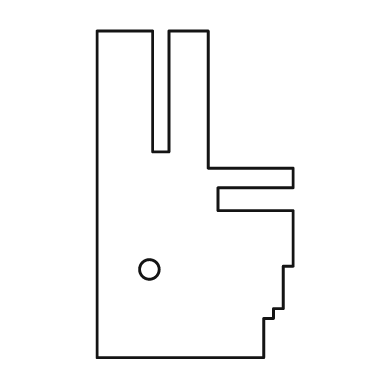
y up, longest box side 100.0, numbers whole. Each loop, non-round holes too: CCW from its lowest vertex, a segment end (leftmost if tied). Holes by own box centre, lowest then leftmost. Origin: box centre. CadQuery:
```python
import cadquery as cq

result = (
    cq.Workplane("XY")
    .moveTo(-30.0, -50.0)
    .lineTo(21.0, -50.0)
    .lineTo(21.0, -38.0)
    .lineTo(24.0, -38.0)
    .lineTo(24.0, -35.0)
    .lineTo(27.0, -35.0)
    .lineTo(27.0, -22.0)
    .lineTo(30.0, -22.0)
    .lineTo(30.0, -5.0)
    .lineTo(7.0, -5.0)
    .lineTo(7.0, 2.0)
    .lineTo(30.0, 2.0)
    .lineTo(30.0, 8.0)
    .lineTo(4.0, 8.0)
    .lineTo(4.0, 50.0)
    .lineTo(-8.0, 50.0)
    .lineTo(-8.0, 13.0)
    .lineTo(-13.0, 13.0)
    .lineTo(-13.0, 50.0)
    .lineTo(-30.0, 50.0)
    .close()
    .moveTo(-14.0, -23.0)
    .circle(3.0)
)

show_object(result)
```